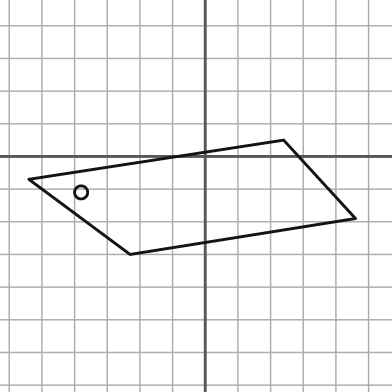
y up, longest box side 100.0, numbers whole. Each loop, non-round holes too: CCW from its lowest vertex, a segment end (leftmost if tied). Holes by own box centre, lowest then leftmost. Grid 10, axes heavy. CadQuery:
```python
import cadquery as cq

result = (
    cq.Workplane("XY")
    .moveTo(-23.0, -30.0)
    .lineTo(46.0, -19.0)
    .lineTo(24.0, 5.0)
    .lineTo(-54.0, -7.0)
    .close()
    .moveTo(-38.0, -11.0)
    .circle(2.0)
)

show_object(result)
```